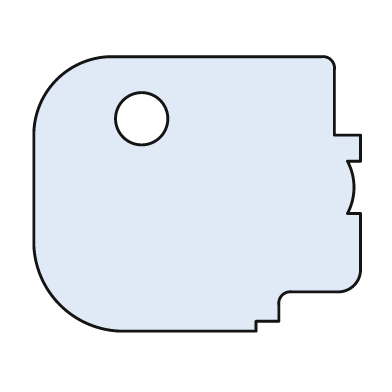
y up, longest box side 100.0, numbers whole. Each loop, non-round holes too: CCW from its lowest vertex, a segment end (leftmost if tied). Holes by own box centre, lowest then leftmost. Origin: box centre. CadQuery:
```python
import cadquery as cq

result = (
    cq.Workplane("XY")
    .moveTo(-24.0, -42.0)
    .lineTo(18.0, -42.0)
    .lineTo(18.0, -39.0)
    .lineTo(25.0, -39.0)
    .lineTo(25.0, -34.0)
    .threePointArc((26.0, -31.0), (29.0, -30.0))
    .lineTo(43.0, -30.0)
    .threePointArc((48.0, -28.0), (50.0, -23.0))
    .lineTo(50.0, -6.0)
    .lineTo(46.0, -6.0)
    .threePointArc((48.0, 2.0), (46.0, 10.0))
    .lineTo(50.0, 10.0)
    .lineTo(50.0, 18.0)
    .lineTo(42.0, 18.0)
    .lineTo(42.0, 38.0)
    .threePointArc((41.0, 41.0), (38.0, 42.0))
    .lineTo(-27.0, 42.0)
    .threePointArc((-43.0, 35.0), (-50.0, 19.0))
    .lineTo(-50.0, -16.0)
    .threePointArc((-42.0, -34.0), (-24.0, -42.0))
    .close()
    .moveTo(-17.0, 23.0)
    .circle(8.0)
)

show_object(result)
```